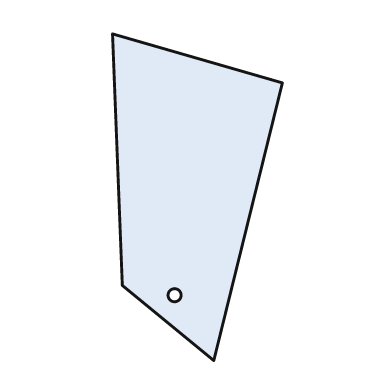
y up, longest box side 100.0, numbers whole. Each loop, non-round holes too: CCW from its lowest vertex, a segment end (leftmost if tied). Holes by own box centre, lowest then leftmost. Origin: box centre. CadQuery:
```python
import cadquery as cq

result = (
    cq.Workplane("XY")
    .moveTo(5.0, -50.0)
    .lineTo(26.0, 35.0)
    .lineTo(-26.0, 50.0)
    .lineTo(-23.0, -27.0)
    .close()
    .moveTo(-7.0, -30.0)
    .circle(2.0)
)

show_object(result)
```